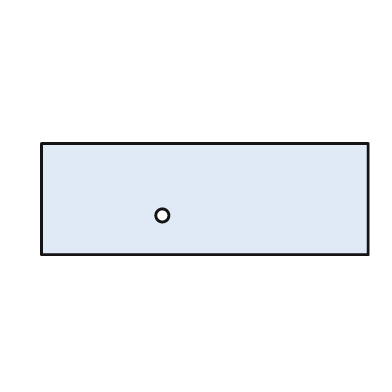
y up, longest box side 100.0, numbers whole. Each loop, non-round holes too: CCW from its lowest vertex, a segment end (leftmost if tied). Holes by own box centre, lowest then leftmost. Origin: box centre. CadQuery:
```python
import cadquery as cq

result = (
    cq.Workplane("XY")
    .moveTo(-50.0, -17.0)
    .lineTo(50.0, -17.0)
    .lineTo(50.0, 17.0)
    .lineTo(-50.0, 17.0)
    .close()
    .moveTo(-13.0, -5.0)
    .circle(2.0)
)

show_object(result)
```